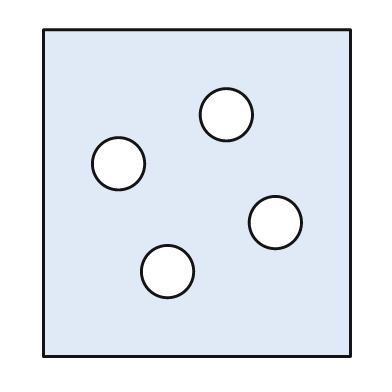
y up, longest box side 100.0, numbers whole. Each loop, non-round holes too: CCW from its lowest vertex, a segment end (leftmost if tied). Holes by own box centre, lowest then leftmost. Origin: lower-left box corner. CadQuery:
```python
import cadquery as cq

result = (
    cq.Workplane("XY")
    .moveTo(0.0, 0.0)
    .lineTo(94.0, 0.0)
    .lineTo(94.0, 100.0)
    .lineTo(0.0, 100.0)
    .close()
    .moveTo(38.0, 26.0)
    .circle(8.0)
    .moveTo(71.0, 41.0)
    .circle(8.0)
    .moveTo(23.0, 59.0)
    .circle(8.0)
    .moveTo(56.0, 74.0)
    .circle(8.0)
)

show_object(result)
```